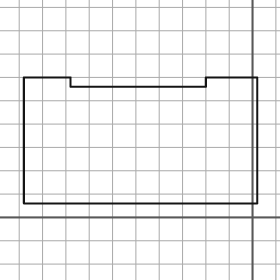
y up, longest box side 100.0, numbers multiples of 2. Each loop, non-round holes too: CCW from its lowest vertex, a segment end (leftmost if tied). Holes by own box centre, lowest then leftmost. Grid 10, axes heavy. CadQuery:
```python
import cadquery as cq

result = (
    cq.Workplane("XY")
    .moveTo(-98.0, 6.0)
    .lineTo(2.0, 6.0)
    .lineTo(2.0, 60.0)
    .lineTo(-20.0, 60.0)
    .lineTo(-20.0, 56.0)
    .lineTo(-78.0, 56.0)
    .lineTo(-78.0, 60.0)
    .lineTo(-98.0, 60.0)
    .close()
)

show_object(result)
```